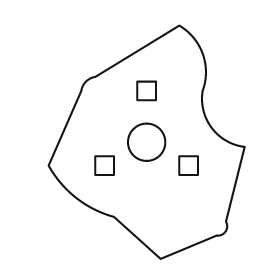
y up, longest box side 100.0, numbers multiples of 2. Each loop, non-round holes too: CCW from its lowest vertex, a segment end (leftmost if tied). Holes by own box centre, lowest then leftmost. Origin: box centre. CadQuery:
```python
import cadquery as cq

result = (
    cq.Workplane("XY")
    .moveTo(6.0, -50.0)
    .lineTo(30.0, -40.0)
    .threePointArc((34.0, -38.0), (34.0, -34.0))
    .lineTo(42.0, -2.0)
    .threePointArc((28.0, 6.0), (24.0, 22.0))
    .threePointArc((24.0, 38.0), (14.0, 50.0))
    .lineTo(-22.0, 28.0)
    .threePointArc((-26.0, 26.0), (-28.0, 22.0))
    .lineTo(-42.0, -10.0)
    .threePointArc((-30.0, -24.0), (-14.0, -32.0))
    .close()
    .moveTo(-22.0, -14.0)
    .lineTo(-14.0, -14.0)
    .lineTo(-14.0, -6.0)
    .lineTo(-22.0, -6.0)
    .close()
    .moveTo(14.0, -14.0)
    .lineTo(22.0, -14.0)
    .lineTo(22.0, -6.0)
    .lineTo(14.0, -6.0)
    .close()
    .moveTo(0.0, 0.0)
    .circle(8.0)
    .moveTo(-4.0, 18.0)
    .lineTo(4.0, 18.0)
    .lineTo(4.0, 26.0)
    .lineTo(-4.0, 26.0)
    .close()
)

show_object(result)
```